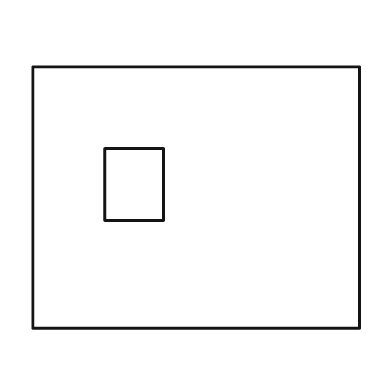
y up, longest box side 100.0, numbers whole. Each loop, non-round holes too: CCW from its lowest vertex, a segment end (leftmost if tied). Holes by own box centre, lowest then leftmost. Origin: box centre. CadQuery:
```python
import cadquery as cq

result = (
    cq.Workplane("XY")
    .moveTo(-50.0, -40.0)
    .lineTo(50.0, -40.0)
    .lineTo(50.0, 40.0)
    .lineTo(-50.0, 40.0)
    .close()
    .moveTo(-28.0, -7.0)
    .lineTo(-10.0, -7.0)
    .lineTo(-10.0, 15.0)
    .lineTo(-28.0, 15.0)
    .close()
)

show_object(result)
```